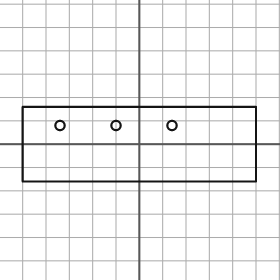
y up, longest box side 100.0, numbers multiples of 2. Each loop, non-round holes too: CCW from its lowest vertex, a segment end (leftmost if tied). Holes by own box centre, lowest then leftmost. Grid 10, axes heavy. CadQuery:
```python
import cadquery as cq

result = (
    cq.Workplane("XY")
    .moveTo(-50.0, -16.0)
    .lineTo(50.0, -16.0)
    .lineTo(50.0, 16.0)
    .lineTo(-50.0, 16.0)
    .close()
    .moveTo(-34.0, 8.0)
    .circle(2.0)
    .moveTo(-10.0, 8.0)
    .circle(2.0)
    .moveTo(14.0, 8.0)
    .circle(2.0)
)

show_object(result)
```